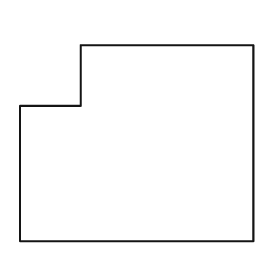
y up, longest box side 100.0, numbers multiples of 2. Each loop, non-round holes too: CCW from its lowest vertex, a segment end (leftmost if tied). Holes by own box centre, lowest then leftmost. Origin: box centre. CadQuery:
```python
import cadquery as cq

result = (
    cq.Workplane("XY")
    .moveTo(-50.0, -42.0)
    .lineTo(50.0, -42.0)
    .lineTo(50.0, 42.0)
    .lineTo(-24.0, 42.0)
    .lineTo(-24.0, 16.0)
    .lineTo(-50.0, 16.0)
    .close()
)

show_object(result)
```